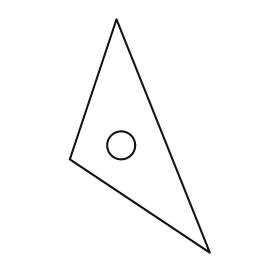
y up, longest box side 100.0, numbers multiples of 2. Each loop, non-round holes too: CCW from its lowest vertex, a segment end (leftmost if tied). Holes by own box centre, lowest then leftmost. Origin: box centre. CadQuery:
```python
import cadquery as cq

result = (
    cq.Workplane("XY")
    .moveTo(30.0, -50.0)
    .lineTo(-10.0, 50.0)
    .lineTo(-30.0, -10.0)
    .close()
    .moveTo(-8.0, -4.0)
    .circle(6.0)
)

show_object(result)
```